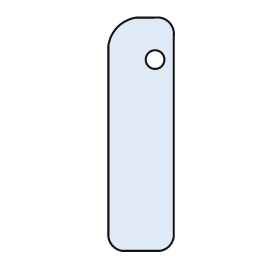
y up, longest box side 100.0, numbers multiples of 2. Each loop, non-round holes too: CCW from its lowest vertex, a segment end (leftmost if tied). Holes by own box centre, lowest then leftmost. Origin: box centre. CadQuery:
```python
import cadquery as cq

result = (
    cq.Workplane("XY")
    .moveTo(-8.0, -50.0)
    .lineTo(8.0, -50.0)
    .threePointArc((12.0, -48.0), (14.0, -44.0))
    .lineTo(14.0, 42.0)
    .threePointArc((12.0, 48.0), (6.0, 50.0))
    .lineTo(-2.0, 50.0)
    .threePointArc((-10.0, 46.0), (-14.0, 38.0))
    .lineTo(-14.0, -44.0)
    .threePointArc((-12.0, -48.0), (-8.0, -50.0))
    .close()
    .moveTo(6.0, 32.0)
    .circle(4.0)
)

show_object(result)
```